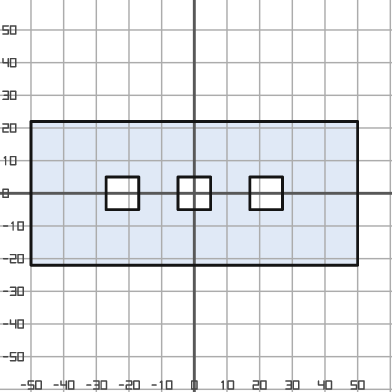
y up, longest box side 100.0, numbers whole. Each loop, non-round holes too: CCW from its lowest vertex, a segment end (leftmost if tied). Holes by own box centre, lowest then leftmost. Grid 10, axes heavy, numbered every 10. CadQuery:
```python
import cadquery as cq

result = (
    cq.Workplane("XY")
    .moveTo(-50.0, -22.0)
    .lineTo(50.0, -22.0)
    .lineTo(50.0, 22.0)
    .lineTo(-50.0, 22.0)
    .close()
    .moveTo(-27.0, -5.0)
    .lineTo(-17.0, -5.0)
    .lineTo(-17.0, 5.0)
    .lineTo(-27.0, 5.0)
    .close()
    .moveTo(-5.0, -5.0)
    .lineTo(5.0, -5.0)
    .lineTo(5.0, 5.0)
    .lineTo(-5.0, 5.0)
    .close()
    .moveTo(17.0, -5.0)
    .lineTo(27.0, -5.0)
    .lineTo(27.0, 5.0)
    .lineTo(17.0, 5.0)
    .close()
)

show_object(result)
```